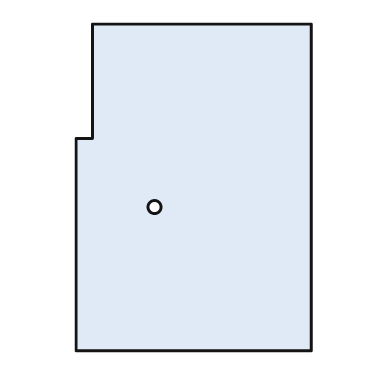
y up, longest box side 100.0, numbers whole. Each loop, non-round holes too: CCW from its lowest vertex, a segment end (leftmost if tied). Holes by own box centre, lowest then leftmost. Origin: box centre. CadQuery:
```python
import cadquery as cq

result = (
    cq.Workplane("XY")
    .moveTo(-36.0, -50.0)
    .lineTo(36.0, -50.0)
    .lineTo(36.0, 50.0)
    .lineTo(-31.0, 50.0)
    .lineTo(-31.0, 15.0)
    .lineTo(-36.0, 15.0)
    .close()
    .moveTo(-12.0, -6.0)
    .circle(2.0)
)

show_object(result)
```